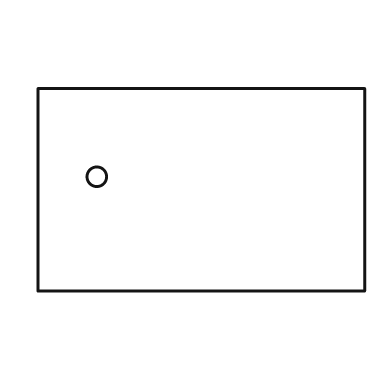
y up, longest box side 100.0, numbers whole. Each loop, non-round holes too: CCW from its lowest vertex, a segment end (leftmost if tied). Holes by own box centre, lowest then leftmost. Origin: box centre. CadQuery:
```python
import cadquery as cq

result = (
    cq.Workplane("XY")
    .moveTo(-50.0, -31.0)
    .lineTo(50.0, -31.0)
    .lineTo(50.0, 31.0)
    .lineTo(-50.0, 31.0)
    .close()
    .moveTo(-32.0, 4.0)
    .circle(3.0)
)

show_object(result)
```